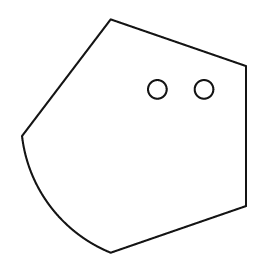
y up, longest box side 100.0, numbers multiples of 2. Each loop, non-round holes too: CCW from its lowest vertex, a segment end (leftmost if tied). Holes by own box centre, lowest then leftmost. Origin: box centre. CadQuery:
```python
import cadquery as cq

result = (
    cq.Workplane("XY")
    .moveTo(-10.0, -50.0)
    .lineTo(48.0, -30.0)
    .lineTo(48.0, 30.0)
    .lineTo(-10.0, 50.0)
    .lineTo(-48.0, 0.0)
    .threePointArc((-36.0, -30.0), (-10.0, -50.0))
    .close()
    .moveTo(10.0, 20.0)
    .circle(4.0)
    .moveTo(30.0, 20.0)
    .circle(4.0)
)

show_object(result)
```